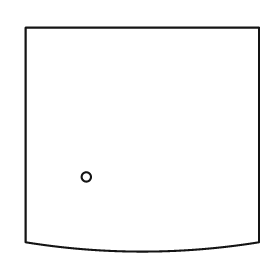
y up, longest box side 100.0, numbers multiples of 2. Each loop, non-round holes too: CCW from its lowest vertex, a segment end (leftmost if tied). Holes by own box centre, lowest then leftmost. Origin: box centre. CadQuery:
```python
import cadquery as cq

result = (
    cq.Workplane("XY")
    .moveTo(-50.0, -44.0)
    .threePointArc((0.0, -48.0), (50.0, -44.0))
    .lineTo(50.0, 48.0)
    .lineTo(-50.0, 48.0)
    .close()
    .moveTo(-24.0, -16.0)
    .circle(2.0)
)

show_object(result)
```